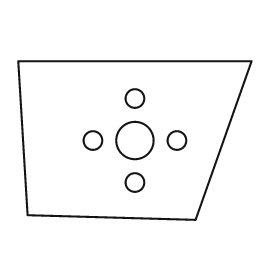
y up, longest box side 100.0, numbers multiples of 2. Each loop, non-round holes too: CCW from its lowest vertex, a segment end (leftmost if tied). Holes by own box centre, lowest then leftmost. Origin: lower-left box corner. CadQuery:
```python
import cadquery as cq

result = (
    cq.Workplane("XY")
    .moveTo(76.0, 0.0)
    .lineTo(100.0, 68.0)
    .lineTo(0.0, 68.0)
    .lineTo(4.0, 2.0)
    .close()
    .moveTo(50.0, 16.0)
    .circle(4.0)
    .moveTo(32.0, 34.0)
    .circle(4.0)
    .moveTo(50.0, 34.0)
    .circle(8.0)
    .moveTo(68.0, 34.0)
    .circle(4.0)
    .moveTo(50.0, 52.0)
    .circle(4.0)
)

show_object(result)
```